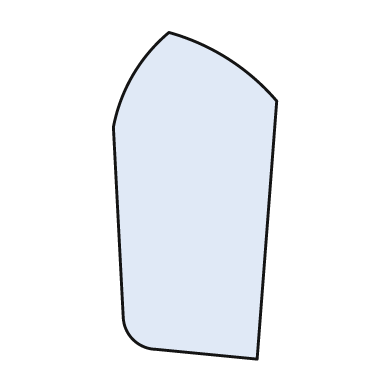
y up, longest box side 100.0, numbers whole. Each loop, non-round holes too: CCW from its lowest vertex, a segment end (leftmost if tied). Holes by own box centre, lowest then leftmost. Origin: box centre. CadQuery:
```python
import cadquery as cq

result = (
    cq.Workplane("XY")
    .moveTo(19.0, -50.0)
    .lineTo(25.0, 29.0)
    .threePointArc((10.0, 42.0), (-8.0, 50.0))
    .threePointArc((-19.0, 37.0), (-25.0, 21.0))
    .lineTo(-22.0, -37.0)
    .threePointArc((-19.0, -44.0), (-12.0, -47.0))
    .close()
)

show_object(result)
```